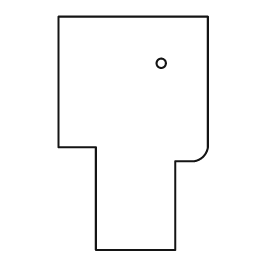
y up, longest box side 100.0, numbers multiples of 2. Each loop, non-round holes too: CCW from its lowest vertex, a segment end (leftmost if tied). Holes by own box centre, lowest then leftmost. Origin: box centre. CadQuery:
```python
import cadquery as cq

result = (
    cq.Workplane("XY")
    .moveTo(-16.0, -50.0)
    .lineTo(18.0, -50.0)
    .lineTo(18.0, -12.0)
    .lineTo(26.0, -12.0)
    .threePointArc((30.0, -10.0), (32.0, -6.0))
    .lineTo(32.0, 50.0)
    .lineTo(-32.0, 50.0)
    .lineTo(-32.0, -6.0)
    .lineTo(-16.0, -6.0)
    .close()
    .moveTo(12.0, 30.0)
    .circle(2.0)
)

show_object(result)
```